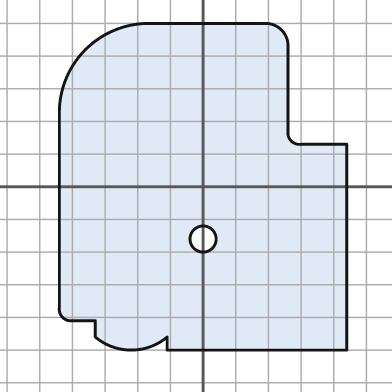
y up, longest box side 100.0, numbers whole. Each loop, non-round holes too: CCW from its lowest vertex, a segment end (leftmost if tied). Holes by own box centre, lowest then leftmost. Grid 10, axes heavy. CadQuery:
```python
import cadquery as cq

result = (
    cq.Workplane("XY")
    .moveTo(-11.0, -50.0)
    .lineTo(44.0, -50.0)
    .lineTo(44.0, 13.0)
    .lineTo(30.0, 13.0)
    .threePointArc((27.0, 14.0), (26.0, 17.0))
    .lineTo(26.0, 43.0)
    .threePointArc((24.0, 48.0), (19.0, 50.0))
    .lineTo(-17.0, 50.0)
    .threePointArc((-36.0, 42.0), (-44.0, 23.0))
    .lineTo(-44.0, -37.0)
    .threePointArc((-43.0, -40.0), (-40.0, -41.0))
    .lineTo(-33.0, -41.0)
    .lineTo(-33.0, -46.0)
    .threePointArc((-22.0, -50.0), (-11.0, -46.0))
    .close()
    .moveTo(0.0, -16.0)
    .circle(4.0)
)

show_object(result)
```